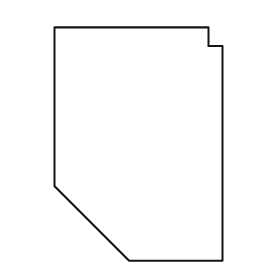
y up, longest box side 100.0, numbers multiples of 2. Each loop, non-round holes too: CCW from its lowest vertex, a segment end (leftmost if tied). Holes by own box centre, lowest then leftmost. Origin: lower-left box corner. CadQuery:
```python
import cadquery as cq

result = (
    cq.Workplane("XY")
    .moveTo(32.0, 0.0)
    .lineTo(72.0, 0.0)
    .lineTo(72.0, 92.0)
    .lineTo(66.0, 92.0)
    .lineTo(66.0, 100.0)
    .lineTo(0.0, 100.0)
    .lineTo(0.0, 32.0)
    .close()
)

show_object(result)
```